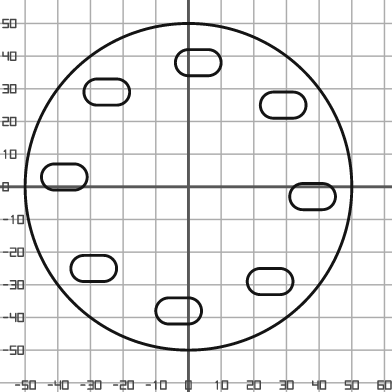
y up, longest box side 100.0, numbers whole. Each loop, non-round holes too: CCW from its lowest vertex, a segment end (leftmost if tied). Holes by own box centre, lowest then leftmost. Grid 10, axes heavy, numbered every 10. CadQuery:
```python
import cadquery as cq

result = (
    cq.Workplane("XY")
    .moveTo(0.0, 0.0)
    .circle(50.0)
    .moveTo(-6.0, -42.0)
    .lineTo(0.0, -42.0)
    .threePointArc((4.0, -38.0), (0.0, -34.0))
    .lineTo(-6.0, -34.0)
    .threePointArc((-10.0, -38.0), (-6.0, -42.0))
    .close()
    .moveTo(22.0, -33.0)
    .lineTo(28.0, -33.0)
    .threePointArc((32.0, -29.0), (28.0, -25.0))
    .lineTo(22.0, -25.0)
    .threePointArc((18.0, -29.0), (22.0, -33.0))
    .close()
    .moveTo(-32.0, -29.0)
    .lineTo(-26.0, -29.0)
    .threePointArc((-22.0, -25.0), (-26.0, -21.0))
    .lineTo(-32.0, -21.0)
    .threePointArc((-36.0, -25.0), (-32.0, -29.0))
    .close()
    .moveTo(35.0, -7.0)
    .lineTo(41.0, -7.0)
    .threePointArc((45.0, -3.0), (41.0, 1.0))
    .lineTo(35.0, 1.0)
    .threePointArc((31.0, -3.0), (35.0, -7.0))
    .close()
    .moveTo(-41.0, -1.0)
    .lineTo(-35.0, -1.0)
    .threePointArc((-31.0, 3.0), (-35.0, 7.0))
    .lineTo(-41.0, 7.0)
    .threePointArc((-45.0, 3.0), (-41.0, -1.0))
    .close()
    .moveTo(26.0, 21.0)
    .lineTo(32.0, 21.0)
    .threePointArc((36.0, 25.0), (32.0, 29.0))
    .lineTo(26.0, 29.0)
    .threePointArc((22.0, 25.0), (26.0, 21.0))
    .close()
    .moveTo(-28.0, 25.0)
    .lineTo(-22.0, 25.0)
    .threePointArc((-18.0, 29.0), (-22.0, 33.0))
    .lineTo(-28.0, 33.0)
    .threePointArc((-32.0, 29.0), (-28.0, 25.0))
    .close()
    .moveTo(0.0, 34.0)
    .lineTo(6.0, 34.0)
    .threePointArc((10.0, 38.0), (6.0, 42.0))
    .lineTo(0.0, 42.0)
    .threePointArc((-4.0, 38.0), (0.0, 34.0))
    .close()
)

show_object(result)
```